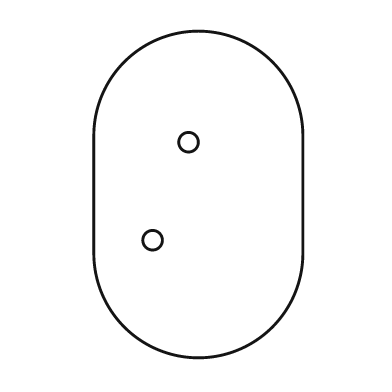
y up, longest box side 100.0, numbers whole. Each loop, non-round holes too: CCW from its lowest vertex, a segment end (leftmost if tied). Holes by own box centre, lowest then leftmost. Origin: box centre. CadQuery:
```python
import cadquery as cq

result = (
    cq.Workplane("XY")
    .moveTo(-32.0, -18.0)
    .threePointArc((0.0, -50.0), (32.0, -18.0))
    .lineTo(32.0, 18.0)
    .threePointArc((0.0, 50.0), (-32.0, 18.0))
    .close()
    .moveTo(-14.0, -14.0)
    .circle(3.0)
    .moveTo(-3.0, 16.0)
    .circle(3.0)
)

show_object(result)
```